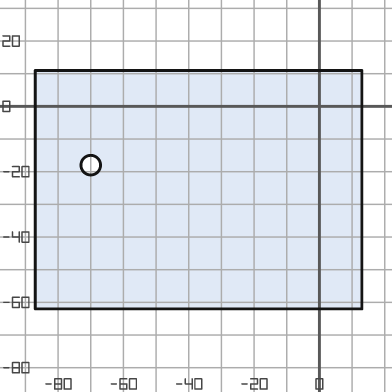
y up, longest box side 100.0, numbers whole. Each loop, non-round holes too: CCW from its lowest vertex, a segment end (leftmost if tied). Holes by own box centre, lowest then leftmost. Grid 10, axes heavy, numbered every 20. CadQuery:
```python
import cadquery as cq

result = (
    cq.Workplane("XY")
    .moveTo(-87.0, -62.0)
    .lineTo(13.0, -62.0)
    .lineTo(13.0, 11.0)
    .lineTo(-87.0, 11.0)
    .close()
    .moveTo(-70.0, -18.0)
    .circle(3.0)
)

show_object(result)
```